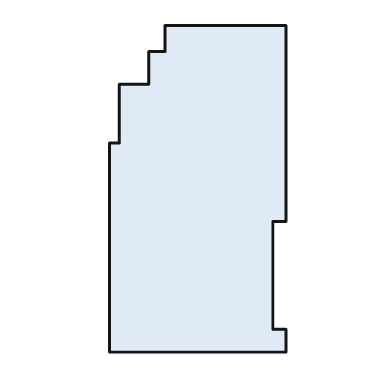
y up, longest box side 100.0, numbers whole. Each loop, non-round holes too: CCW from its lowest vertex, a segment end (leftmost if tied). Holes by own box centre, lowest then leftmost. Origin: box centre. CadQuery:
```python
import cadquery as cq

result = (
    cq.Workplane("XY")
    .moveTo(-27.0, -50.0)
    .lineTo(27.0, -50.0)
    .lineTo(27.0, -43.0)
    .lineTo(23.0, -43.0)
    .lineTo(23.0, -10.0)
    .lineTo(27.0, -10.0)
    .lineTo(27.0, 50.0)
    .lineTo(-10.0, 50.0)
    .lineTo(-10.0, 42.0)
    .lineTo(-15.0, 42.0)
    .lineTo(-15.0, 32.0)
    .lineTo(-24.0, 32.0)
    .lineTo(-24.0, 14.0)
    .lineTo(-27.0, 14.0)
    .close()
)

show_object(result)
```